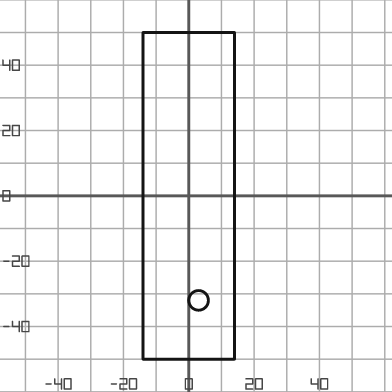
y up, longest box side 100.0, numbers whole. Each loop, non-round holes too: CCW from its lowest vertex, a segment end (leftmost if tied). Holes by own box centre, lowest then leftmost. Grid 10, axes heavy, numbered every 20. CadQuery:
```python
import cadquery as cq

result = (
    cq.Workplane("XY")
    .moveTo(-14.0, -50.0)
    .lineTo(14.0, -50.0)
    .lineTo(14.0, 50.0)
    .lineTo(-14.0, 50.0)
    .close()
    .moveTo(3.0, -32.0)
    .circle(3.0)
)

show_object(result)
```